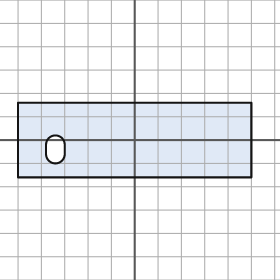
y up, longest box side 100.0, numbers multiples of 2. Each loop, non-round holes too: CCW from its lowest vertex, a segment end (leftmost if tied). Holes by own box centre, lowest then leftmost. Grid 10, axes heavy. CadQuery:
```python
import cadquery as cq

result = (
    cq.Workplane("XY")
    .moveTo(-50.0, -16.0)
    .lineTo(50.0, -16.0)
    .lineTo(50.0, 16.0)
    .lineTo(-50.0, 16.0)
    .close()
    .moveTo(-38.0, -6.0)
    .threePointArc((-34.0, -10.0), (-30.0, -6.0))
    .lineTo(-30.0, -2.0)
    .threePointArc((-34.0, 2.0), (-38.0, -2.0))
    .close()
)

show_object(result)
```